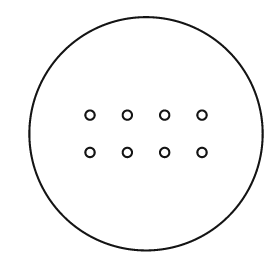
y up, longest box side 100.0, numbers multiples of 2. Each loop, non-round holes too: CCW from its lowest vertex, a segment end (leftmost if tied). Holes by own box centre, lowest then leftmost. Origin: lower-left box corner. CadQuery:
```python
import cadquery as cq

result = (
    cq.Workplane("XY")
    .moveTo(50.0, 50.0)
    .circle(50.0)
    .moveTo(26.0, 42.0)
    .circle(2.0)
    .moveTo(42.0, 42.0)
    .circle(2.0)
    .moveTo(58.0, 42.0)
    .circle(2.0)
    .moveTo(74.0, 42.0)
    .circle(2.0)
    .moveTo(26.0, 58.0)
    .circle(2.0)
    .moveTo(42.0, 58.0)
    .circle(2.0)
    .moveTo(58.0, 58.0)
    .circle(2.0)
    .moveTo(74.0, 58.0)
    .circle(2.0)
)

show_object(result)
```